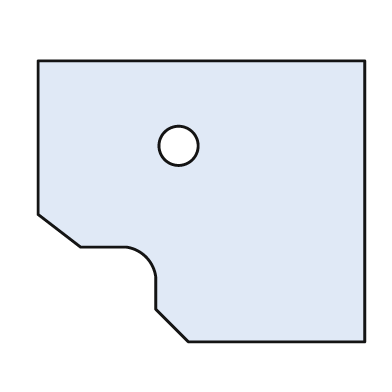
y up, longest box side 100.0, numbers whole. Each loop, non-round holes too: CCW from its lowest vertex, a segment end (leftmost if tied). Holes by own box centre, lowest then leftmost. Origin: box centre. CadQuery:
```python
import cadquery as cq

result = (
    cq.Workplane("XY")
    .moveTo(-4.0, -43.0)
    .lineTo(50.0, -43.0)
    .lineTo(50.0, 43.0)
    .lineTo(-50.0, 43.0)
    .lineTo(-50.0, -4.0)
    .lineTo(-37.0, -14.0)
    .lineTo(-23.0, -14.0)
    .threePointArc((-17.0, -17.0), (-14.0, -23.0))
    .lineTo(-14.0, -33.0)
    .close()
    .moveTo(-7.0, 17.0)
    .circle(6.0)
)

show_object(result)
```